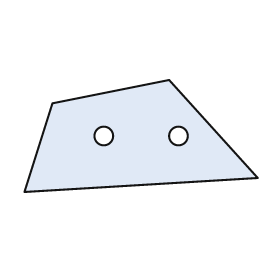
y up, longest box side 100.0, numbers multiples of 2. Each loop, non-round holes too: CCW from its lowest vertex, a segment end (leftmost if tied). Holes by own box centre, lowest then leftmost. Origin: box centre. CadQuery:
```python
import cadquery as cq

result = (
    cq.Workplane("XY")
    .moveTo(-50.0, -24.0)
    .lineTo(50.0, -18.0)
    .lineTo(12.0, 24.0)
    .lineTo(-38.0, 14.0)
    .close()
    .moveTo(-16.0, 0.0)
    .circle(4.0)
    .moveTo(16.0, 0.0)
    .circle(4.0)
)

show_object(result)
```